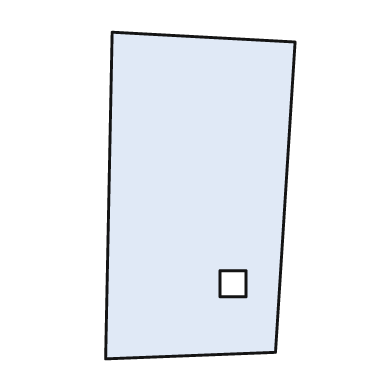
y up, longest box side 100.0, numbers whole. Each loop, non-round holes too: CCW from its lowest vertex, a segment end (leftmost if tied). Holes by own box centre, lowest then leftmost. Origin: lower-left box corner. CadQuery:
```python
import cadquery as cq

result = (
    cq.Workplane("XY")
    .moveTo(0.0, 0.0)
    .lineTo(52.0, 2.0)
    .lineTo(58.0, 97.0)
    .lineTo(2.0, 100.0)
    .close()
    .moveTo(35.0, 19.0)
    .lineTo(43.0, 19.0)
    .lineTo(43.0, 27.0)
    .lineTo(35.0, 27.0)
    .close()
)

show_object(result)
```